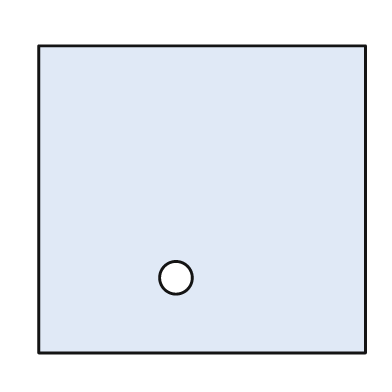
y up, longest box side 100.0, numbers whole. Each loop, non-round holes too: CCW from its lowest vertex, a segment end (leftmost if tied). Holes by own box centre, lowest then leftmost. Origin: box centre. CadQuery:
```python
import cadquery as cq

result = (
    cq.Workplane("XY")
    .moveTo(-50.0, -47.0)
    .lineTo(50.0, -47.0)
    .lineTo(50.0, 47.0)
    .lineTo(-50.0, 47.0)
    .close()
    .moveTo(-8.0, -24.0)
    .circle(5.0)
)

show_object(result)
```